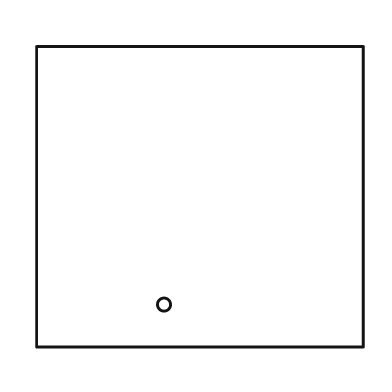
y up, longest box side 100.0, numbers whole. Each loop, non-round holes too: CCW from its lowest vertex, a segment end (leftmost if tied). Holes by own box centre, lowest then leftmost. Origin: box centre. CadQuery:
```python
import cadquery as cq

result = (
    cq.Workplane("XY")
    .moveTo(-50.0, -46.0)
    .lineTo(50.0, -46.0)
    .lineTo(50.0, 46.0)
    .lineTo(-50.0, 46.0)
    .close()
    .moveTo(-11.0, -33.0)
    .circle(2.0)
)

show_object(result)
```